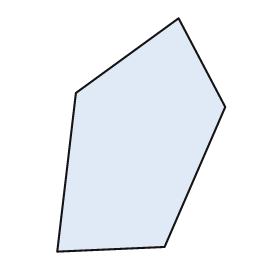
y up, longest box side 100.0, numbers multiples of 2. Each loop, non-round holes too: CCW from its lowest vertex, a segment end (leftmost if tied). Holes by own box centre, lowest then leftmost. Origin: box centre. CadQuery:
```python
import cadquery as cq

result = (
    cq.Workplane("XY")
    .moveTo(-36.0, -50.0)
    .lineTo(10.0, -48.0)
    .lineTo(36.0, 12.0)
    .lineTo(16.0, 50.0)
    .lineTo(-28.0, 18.0)
    .close()
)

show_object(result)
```